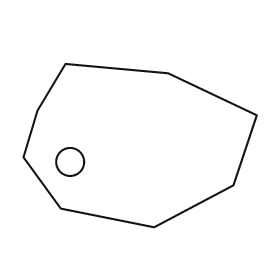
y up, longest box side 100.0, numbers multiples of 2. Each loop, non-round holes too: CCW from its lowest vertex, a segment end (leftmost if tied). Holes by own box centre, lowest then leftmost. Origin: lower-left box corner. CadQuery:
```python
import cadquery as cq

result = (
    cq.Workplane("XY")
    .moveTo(56.0, 0.0)
    .lineTo(90.0, 18.0)
    .lineTo(100.0, 48.0)
    .lineTo(62.0, 66.0)
    .lineTo(18.0, 70.0)
    .lineTo(6.0, 50.0)
    .lineTo(0.0, 30.0)
    .lineTo(16.0, 8.0)
    .close()
    .moveTo(20.0, 28.0)
    .circle(6.0)
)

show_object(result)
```